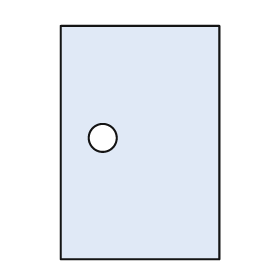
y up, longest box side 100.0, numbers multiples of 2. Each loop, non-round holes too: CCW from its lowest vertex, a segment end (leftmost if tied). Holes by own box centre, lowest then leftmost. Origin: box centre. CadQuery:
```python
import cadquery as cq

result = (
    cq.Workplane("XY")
    .moveTo(-34.0, -50.0)
    .lineTo(34.0, -50.0)
    .lineTo(34.0, 50.0)
    .lineTo(-34.0, 50.0)
    .close()
    .moveTo(-16.0, 2.0)
    .circle(6.0)
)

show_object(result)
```